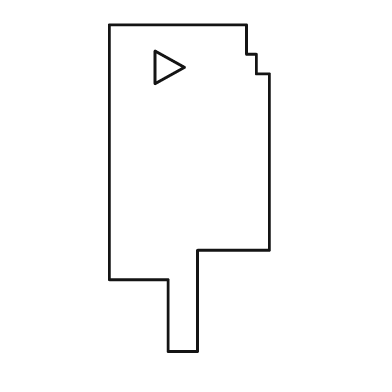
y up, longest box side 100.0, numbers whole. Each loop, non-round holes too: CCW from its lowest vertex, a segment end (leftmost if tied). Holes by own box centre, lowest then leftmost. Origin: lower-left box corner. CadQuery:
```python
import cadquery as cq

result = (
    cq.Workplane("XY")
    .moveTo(18.0, 0.0)
    .lineTo(27.0, 0.0)
    .lineTo(27.0, 31.0)
    .lineTo(49.0, 31.0)
    .lineTo(49.0, 85.0)
    .lineTo(45.0, 85.0)
    .lineTo(45.0, 91.0)
    .lineTo(42.0, 91.0)
    .lineTo(42.0, 100.0)
    .lineTo(0.0, 100.0)
    .lineTo(0.0, 22.0)
    .lineTo(18.0, 22.0)
    .close()
    .moveTo(14.0, 82.0)
    .lineTo(23.0, 87.0)
    .lineTo(14.0, 92.0)
    .close()
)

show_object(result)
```